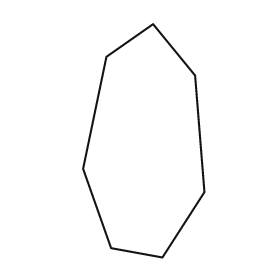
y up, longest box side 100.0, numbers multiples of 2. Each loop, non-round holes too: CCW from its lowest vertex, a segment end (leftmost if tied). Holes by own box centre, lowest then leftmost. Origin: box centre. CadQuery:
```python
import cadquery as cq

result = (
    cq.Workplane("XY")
    .moveTo(8.0, -50.0)
    .lineTo(26.0, -22.0)
    .lineTo(22.0, 28.0)
    .lineTo(4.0, 50.0)
    .lineTo(-16.0, 36.0)
    .lineTo(-26.0, -12.0)
    .lineTo(-14.0, -46.0)
    .close()
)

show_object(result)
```